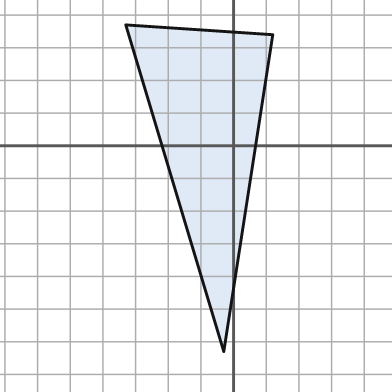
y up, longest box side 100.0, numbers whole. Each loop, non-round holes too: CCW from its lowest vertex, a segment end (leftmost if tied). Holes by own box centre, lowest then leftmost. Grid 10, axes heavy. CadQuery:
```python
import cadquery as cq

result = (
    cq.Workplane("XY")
    .moveTo(-3.0, -63.0)
    .lineTo(12.0, 34.0)
    .lineTo(-33.0, 37.0)
    .close()
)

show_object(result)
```